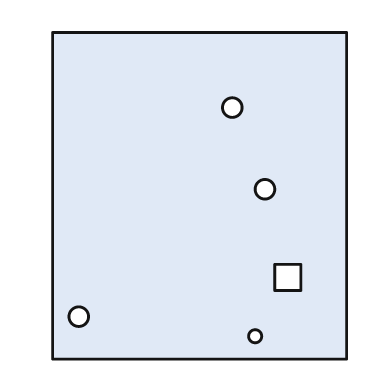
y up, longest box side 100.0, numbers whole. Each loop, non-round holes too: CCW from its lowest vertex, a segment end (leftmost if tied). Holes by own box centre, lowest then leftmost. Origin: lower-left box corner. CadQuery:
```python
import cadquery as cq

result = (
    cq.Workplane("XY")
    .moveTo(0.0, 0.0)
    .lineTo(90.0, 0.0)
    .lineTo(90.0, 100.0)
    .lineTo(0.0, 100.0)
    .close()
    .moveTo(62.0, 7.0)
    .circle(2.0)
    .moveTo(8.0, 13.0)
    .circle(3.0)
    .moveTo(68.0, 21.0)
    .lineTo(76.0, 21.0)
    .lineTo(76.0, 29.0)
    .lineTo(68.0, 29.0)
    .close()
    .moveTo(65.0, 52.0)
    .circle(3.0)
    .moveTo(55.0, 77.0)
    .circle(3.0)
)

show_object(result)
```